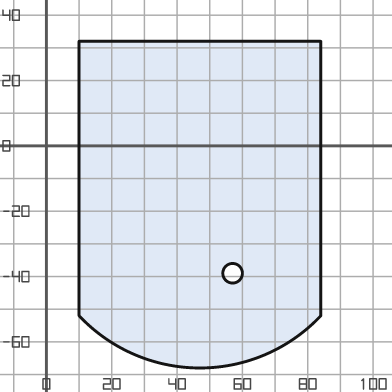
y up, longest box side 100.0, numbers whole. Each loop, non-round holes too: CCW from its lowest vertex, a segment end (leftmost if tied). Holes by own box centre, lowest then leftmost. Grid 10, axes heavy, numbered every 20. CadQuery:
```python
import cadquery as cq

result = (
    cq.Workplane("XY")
    .moveTo(10.0, -52.0)
    .threePointArc((47.0, -68.0), (84.0, -52.0))
    .lineTo(84.0, 32.0)
    .lineTo(10.0, 32.0)
    .close()
    .moveTo(57.0, -39.0)
    .circle(3.0)
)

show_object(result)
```